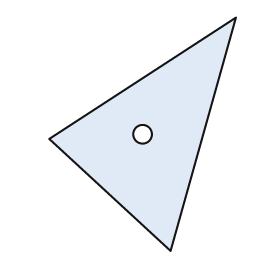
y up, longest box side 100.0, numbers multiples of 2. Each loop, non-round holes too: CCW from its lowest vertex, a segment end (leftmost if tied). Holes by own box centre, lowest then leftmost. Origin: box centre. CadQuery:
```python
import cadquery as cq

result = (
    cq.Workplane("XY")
    .moveTo(12.0, -50.0)
    .lineTo(40.0, 50.0)
    .lineTo(-40.0, -2.0)
    .close()
    .moveTo(0.0, 0.0)
    .circle(4.0)
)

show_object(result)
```